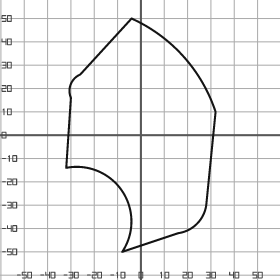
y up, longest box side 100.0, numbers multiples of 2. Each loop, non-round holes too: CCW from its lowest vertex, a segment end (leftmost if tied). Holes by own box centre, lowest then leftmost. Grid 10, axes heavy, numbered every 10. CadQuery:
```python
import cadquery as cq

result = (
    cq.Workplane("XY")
    .moveTo(-8.0, -50.0)
    .lineTo(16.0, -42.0)
    .threePointArc((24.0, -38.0), (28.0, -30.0))
    .lineTo(32.0, 10.0)
    .threePointArc((18.0, 34.0), (-4.0, 50.0))
    .lineTo(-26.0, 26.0)
    .threePointArc((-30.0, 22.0), (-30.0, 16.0))
    .lineTo(-32.0, -14.0)
    .threePointArc((-8.0, -24.0), (-8.0, -50.0))
    .close()
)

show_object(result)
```